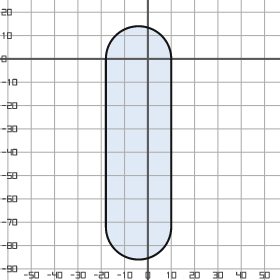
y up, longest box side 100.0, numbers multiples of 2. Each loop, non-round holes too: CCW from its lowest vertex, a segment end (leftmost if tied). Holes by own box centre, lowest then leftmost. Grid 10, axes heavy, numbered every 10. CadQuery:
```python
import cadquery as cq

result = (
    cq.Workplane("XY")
    .moveTo(-18.0, -72.0)
    .threePointArc((-4.0, -86.0), (10.0, -72.0))
    .lineTo(10.0, 0.0)
    .threePointArc((-4.0, 14.0), (-18.0, 0.0))
    .close()
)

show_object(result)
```